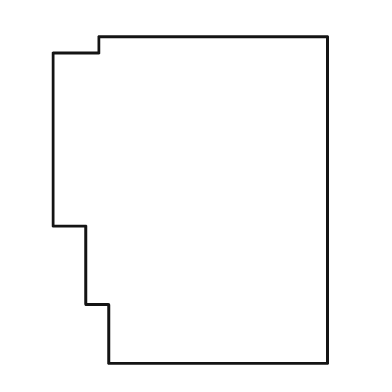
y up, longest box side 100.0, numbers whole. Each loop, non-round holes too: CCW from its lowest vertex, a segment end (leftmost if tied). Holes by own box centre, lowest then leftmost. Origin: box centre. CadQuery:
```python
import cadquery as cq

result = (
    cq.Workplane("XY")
    .moveTo(-25.0, -50.0)
    .lineTo(42.0, -50.0)
    .lineTo(42.0, 50.0)
    .lineTo(-28.0, 50.0)
    .lineTo(-28.0, 45.0)
    .lineTo(-42.0, 45.0)
    .lineTo(-42.0, -8.0)
    .lineTo(-32.0, -8.0)
    .lineTo(-32.0, -32.0)
    .lineTo(-25.0, -32.0)
    .close()
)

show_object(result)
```